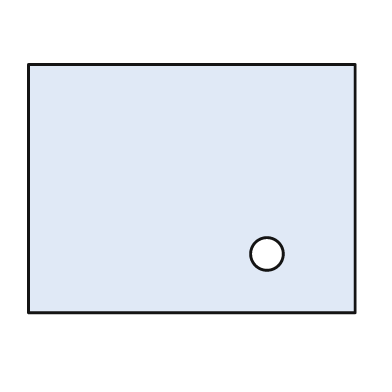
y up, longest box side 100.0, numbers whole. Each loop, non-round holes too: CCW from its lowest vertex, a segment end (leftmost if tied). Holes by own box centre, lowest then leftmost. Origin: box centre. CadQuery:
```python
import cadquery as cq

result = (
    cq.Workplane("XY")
    .moveTo(-50.0, -38.0)
    .lineTo(50.0, -38.0)
    .lineTo(50.0, 38.0)
    .lineTo(-50.0, 38.0)
    .close()
    .moveTo(23.0, -20.0)
    .circle(5.0)
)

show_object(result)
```